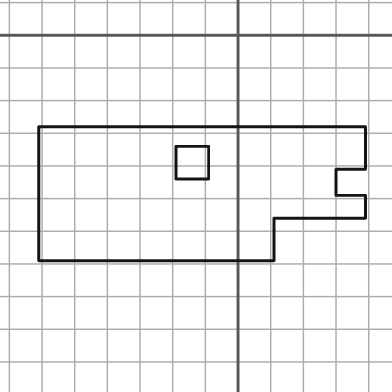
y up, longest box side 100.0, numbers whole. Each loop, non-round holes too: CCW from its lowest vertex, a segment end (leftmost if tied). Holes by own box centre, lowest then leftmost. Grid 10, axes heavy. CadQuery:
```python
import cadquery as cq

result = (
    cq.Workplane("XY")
    .moveTo(-61.0, -69.0)
    .lineTo(11.0, -69.0)
    .lineTo(11.0, -56.0)
    .lineTo(39.0, -56.0)
    .lineTo(39.0, -49.0)
    .lineTo(30.0, -49.0)
    .lineTo(30.0, -41.0)
    .lineTo(39.0, -41.0)
    .lineTo(39.0, -28.0)
    .lineTo(-61.0, -28.0)
    .close()
    .moveTo(-19.0, -44.0)
    .lineTo(-9.0, -44.0)
    .lineTo(-9.0, -34.0)
    .lineTo(-19.0, -34.0)
    .close()
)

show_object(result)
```